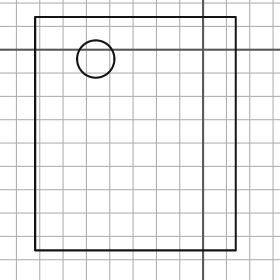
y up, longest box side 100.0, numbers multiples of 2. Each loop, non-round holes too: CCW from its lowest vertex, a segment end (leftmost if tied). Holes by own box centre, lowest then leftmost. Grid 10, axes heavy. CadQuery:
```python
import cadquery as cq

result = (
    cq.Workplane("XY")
    .moveTo(-72.0, -86.0)
    .lineTo(14.0, -86.0)
    .lineTo(14.0, 14.0)
    .lineTo(-72.0, 14.0)
    .close()
    .moveTo(-46.0, -4.0)
    .circle(8.0)
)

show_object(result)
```